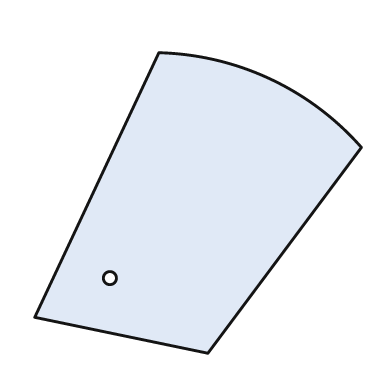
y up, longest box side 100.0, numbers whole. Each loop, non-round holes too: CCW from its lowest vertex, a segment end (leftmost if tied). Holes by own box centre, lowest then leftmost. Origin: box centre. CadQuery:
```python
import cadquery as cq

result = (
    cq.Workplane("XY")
    .moveTo(3.0, -46.0)
    .lineTo(50.0, 17.0)
    .threePointArc((22.0, 38.0), (-12.0, 46.0))
    .lineTo(-50.0, -35.0)
    .close()
    .moveTo(-27.0, -23.0)
    .circle(2.0)
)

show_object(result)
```